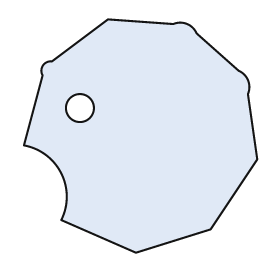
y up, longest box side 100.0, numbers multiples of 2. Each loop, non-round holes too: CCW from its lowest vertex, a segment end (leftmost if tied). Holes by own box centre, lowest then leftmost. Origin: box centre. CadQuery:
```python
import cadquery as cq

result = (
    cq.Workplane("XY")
    .moveTo(-2.0, -50.0)
    .lineTo(30.0, -40.0)
    .lineTo(50.0, -10.0)
    .lineTo(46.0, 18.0)
    .threePointArc((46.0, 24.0), (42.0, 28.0))
    .lineTo(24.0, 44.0)
    .threePointArc((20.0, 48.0), (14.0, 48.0))
    .lineTo(-14.0, 50.0)
    .lineTo(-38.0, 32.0)
    .threePointArc((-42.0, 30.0), (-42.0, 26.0))
    .lineTo(-50.0, -4.0)
    .threePointArc((-34.0, -16.0), (-34.0, -36.0))
    .close()
    .moveTo(-26.0, 12.0)
    .circle(6.0)
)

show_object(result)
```